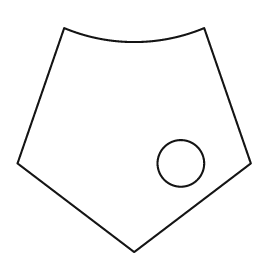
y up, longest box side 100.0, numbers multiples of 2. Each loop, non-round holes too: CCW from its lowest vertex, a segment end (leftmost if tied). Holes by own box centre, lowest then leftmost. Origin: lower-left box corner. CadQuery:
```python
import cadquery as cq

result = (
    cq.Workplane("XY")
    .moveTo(50.0, 0.0)
    .lineTo(100.0, 38.0)
    .lineTo(80.0, 96.0)
    .threePointArc((50.0, 90.0), (20.0, 96.0))
    .lineTo(0.0, 38.0)
    .close()
    .moveTo(70.0, 38.0)
    .circle(10.0)
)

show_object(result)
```